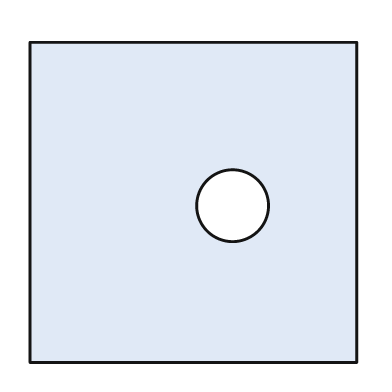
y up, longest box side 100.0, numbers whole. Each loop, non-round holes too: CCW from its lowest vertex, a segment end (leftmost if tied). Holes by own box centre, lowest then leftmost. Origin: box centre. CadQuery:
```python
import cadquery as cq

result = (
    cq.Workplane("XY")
    .moveTo(-50.0, -49.0)
    .lineTo(50.0, -49.0)
    .lineTo(50.0, 49.0)
    .lineTo(-50.0, 49.0)
    .close()
    .moveTo(12.0, -1.0)
    .circle(11.0)
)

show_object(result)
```